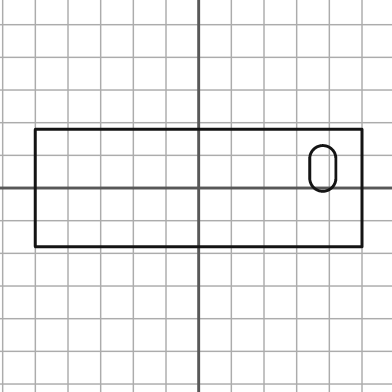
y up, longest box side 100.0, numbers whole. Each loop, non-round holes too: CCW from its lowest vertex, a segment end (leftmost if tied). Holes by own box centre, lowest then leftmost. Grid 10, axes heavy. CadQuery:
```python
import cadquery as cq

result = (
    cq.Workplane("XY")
    .moveTo(-50.0, -18.0)
    .lineTo(50.0, -18.0)
    .lineTo(50.0, 18.0)
    .lineTo(-50.0, 18.0)
    .close()
    .moveTo(34.0, 3.0)
    .threePointArc((38.0, -1.0), (42.0, 3.0))
    .lineTo(42.0, 9.0)
    .threePointArc((38.0, 13.0), (34.0, 9.0))
    .close()
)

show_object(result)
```